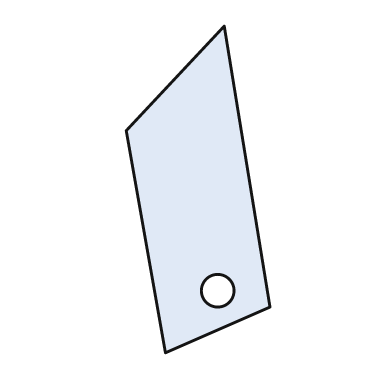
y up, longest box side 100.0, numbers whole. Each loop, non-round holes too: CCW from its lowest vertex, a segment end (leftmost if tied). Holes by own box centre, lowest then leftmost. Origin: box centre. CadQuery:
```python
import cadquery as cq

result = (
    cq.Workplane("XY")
    .moveTo(-10.0, -50.0)
    .lineTo(22.0, -36.0)
    .lineTo(8.0, 50.0)
    .lineTo(-22.0, 18.0)
    .close()
    .moveTo(6.0, -31.0)
    .circle(5.0)
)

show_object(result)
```